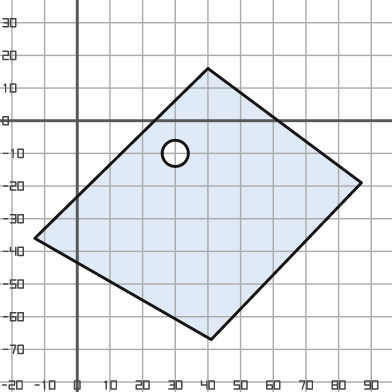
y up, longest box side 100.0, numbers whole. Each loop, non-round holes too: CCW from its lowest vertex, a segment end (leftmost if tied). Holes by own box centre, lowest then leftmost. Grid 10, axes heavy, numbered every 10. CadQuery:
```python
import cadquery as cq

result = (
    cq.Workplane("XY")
    .moveTo(41.0, -67.0)
    .lineTo(87.0, -19.0)
    .lineTo(40.0, 16.0)
    .lineTo(-13.0, -36.0)
    .close()
    .moveTo(30.0, -10.0)
    .circle(4.0)
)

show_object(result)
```